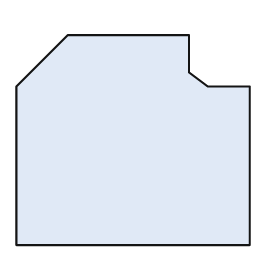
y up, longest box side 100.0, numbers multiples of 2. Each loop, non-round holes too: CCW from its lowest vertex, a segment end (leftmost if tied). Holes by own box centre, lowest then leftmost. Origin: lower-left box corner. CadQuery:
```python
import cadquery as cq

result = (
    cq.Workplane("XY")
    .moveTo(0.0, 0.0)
    .lineTo(100.0, 0.0)
    .lineTo(100.0, 68.0)
    .lineTo(82.0, 68.0)
    .lineTo(74.0, 74.0)
    .lineTo(74.0, 90.0)
    .lineTo(22.0, 90.0)
    .lineTo(0.0, 68.0)
    .close()
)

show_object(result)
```